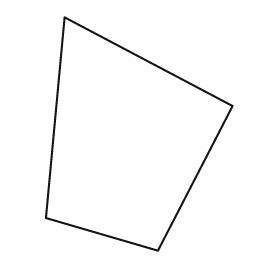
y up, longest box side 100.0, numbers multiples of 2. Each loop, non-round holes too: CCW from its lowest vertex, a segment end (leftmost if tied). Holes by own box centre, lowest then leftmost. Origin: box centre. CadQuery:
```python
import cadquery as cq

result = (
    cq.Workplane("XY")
    .moveTo(8.0, -50.0)
    .lineTo(40.0, 12.0)
    .lineTo(-32.0, 50.0)
    .lineTo(-40.0, -36.0)
    .close()
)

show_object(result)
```